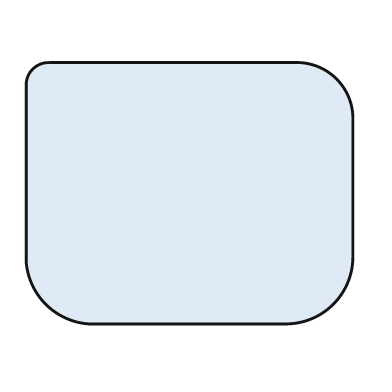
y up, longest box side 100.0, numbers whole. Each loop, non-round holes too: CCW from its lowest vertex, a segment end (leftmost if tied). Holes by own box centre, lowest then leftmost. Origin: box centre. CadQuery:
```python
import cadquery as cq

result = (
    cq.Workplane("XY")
    .moveTo(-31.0, -40.0)
    .lineTo(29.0, -40.0)
    .threePointArc((44.0, -34.0), (50.0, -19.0))
    .lineTo(50.0, 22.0)
    .threePointArc((45.0, 35.0), (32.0, 40.0))
    .lineTo(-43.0, 40.0)
    .threePointArc((-48.0, 38.0), (-50.0, 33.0))
    .lineTo(-50.0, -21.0)
    .threePointArc((-44.0, -34.0), (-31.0, -40.0))
    .close()
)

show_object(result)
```